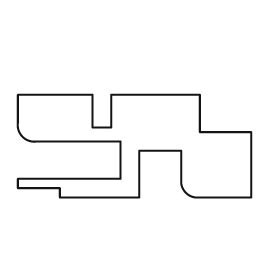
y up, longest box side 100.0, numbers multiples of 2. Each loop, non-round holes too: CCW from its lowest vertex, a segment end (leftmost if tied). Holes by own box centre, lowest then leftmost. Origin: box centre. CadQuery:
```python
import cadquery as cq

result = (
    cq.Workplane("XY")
    .moveTo(-32.0, -22.0)
    .lineTo(2.0, -22.0)
    .lineTo(2.0, -2.0)
    .lineTo(20.0, -2.0)
    .lineTo(20.0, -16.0)
    .threePointArc((22.0, -20.0), (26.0, -22.0))
    .lineTo(50.0, -22.0)
    .lineTo(50.0, 6.0)
    .lineTo(28.0, 6.0)
    .lineTo(28.0, 22.0)
    .lineTo(-10.0, 22.0)
    .lineTo(-10.0, 8.0)
    .lineTo(-18.0, 8.0)
    .lineTo(-18.0, 22.0)
    .lineTo(-50.0, 22.0)
    .lineTo(-50.0, 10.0)
    .threePointArc((-48.0, 4.0), (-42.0, 2.0))
    .lineTo(-6.0, 2.0)
    .lineTo(-6.0, -14.0)
    .lineTo(-50.0, -14.0)
    .lineTo(-50.0, -18.0)
    .lineTo(-32.0, -18.0)
    .close()
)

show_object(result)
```